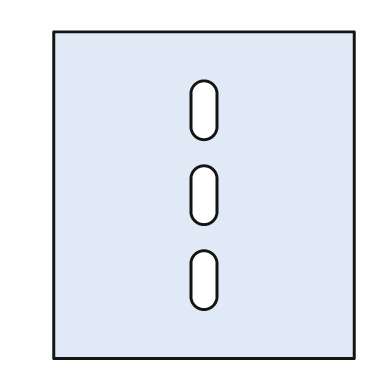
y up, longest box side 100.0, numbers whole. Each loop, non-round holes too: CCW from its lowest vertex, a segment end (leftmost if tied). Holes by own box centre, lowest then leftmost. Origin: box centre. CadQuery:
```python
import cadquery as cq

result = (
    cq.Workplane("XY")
    .moveTo(-46.0, -50.0)
    .lineTo(46.0, -50.0)
    .lineTo(46.0, 50.0)
    .lineTo(-46.0, 50.0)
    .close()
    .moveTo(-4.0, -31.0)
    .threePointArc((0.0, -35.0), (4.0, -31.0))
    .lineTo(4.0, -21.0)
    .threePointArc((0.0, -17.0), (-4.0, -21.0))
    .close()
    .moveTo(-4.0, -5.0)
    .threePointArc((0.0, -9.0), (4.0, -5.0))
    .lineTo(4.0, 5.0)
    .threePointArc((0.0, 9.0), (-4.0, 5.0))
    .close()
    .moveTo(-4.0, 21.0)
    .threePointArc((0.0, 17.0), (4.0, 21.0))
    .lineTo(4.0, 31.0)
    .threePointArc((0.0, 35.0), (-4.0, 31.0))
    .close()
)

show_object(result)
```